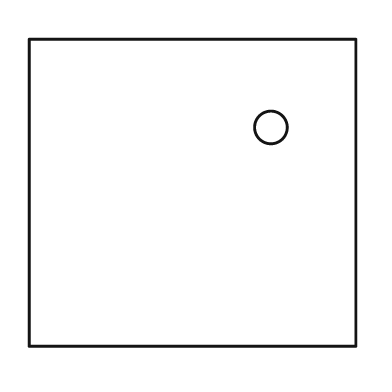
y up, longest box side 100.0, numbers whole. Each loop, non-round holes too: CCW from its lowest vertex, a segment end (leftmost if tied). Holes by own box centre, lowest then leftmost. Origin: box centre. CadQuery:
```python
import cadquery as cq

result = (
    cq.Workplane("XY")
    .moveTo(-50.0, -47.0)
    .lineTo(50.0, -47.0)
    .lineTo(50.0, 47.0)
    .lineTo(-50.0, 47.0)
    .close()
    .moveTo(24.0, 20.0)
    .circle(5.0)
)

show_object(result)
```